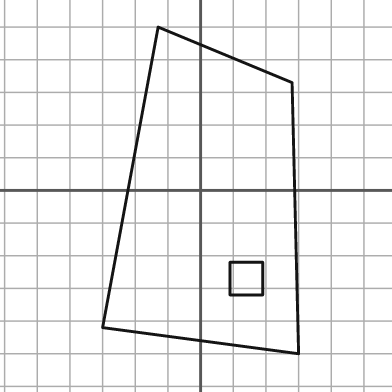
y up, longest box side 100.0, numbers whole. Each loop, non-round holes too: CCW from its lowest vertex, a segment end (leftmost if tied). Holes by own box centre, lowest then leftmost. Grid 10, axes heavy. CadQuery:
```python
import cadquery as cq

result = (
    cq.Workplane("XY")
    .moveTo(30.0, -50.0)
    .lineTo(28.0, 33.0)
    .lineTo(-13.0, 50.0)
    .lineTo(-30.0, -42.0)
    .close()
    .moveTo(9.0, -32.0)
    .lineTo(19.0, -32.0)
    .lineTo(19.0, -22.0)
    .lineTo(9.0, -22.0)
    .close()
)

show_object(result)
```